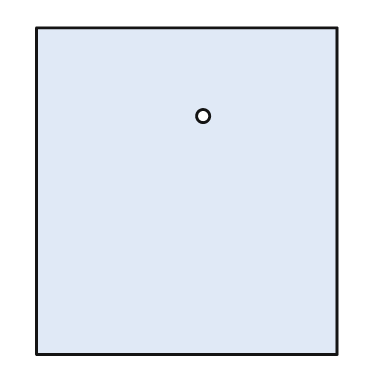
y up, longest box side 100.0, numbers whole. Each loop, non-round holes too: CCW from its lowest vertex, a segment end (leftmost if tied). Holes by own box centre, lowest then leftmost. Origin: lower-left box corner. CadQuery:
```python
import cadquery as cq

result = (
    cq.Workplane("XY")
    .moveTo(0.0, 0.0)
    .lineTo(92.0, 0.0)
    .lineTo(92.0, 100.0)
    .lineTo(0.0, 100.0)
    .close()
    .moveTo(51.0, 73.0)
    .circle(2.0)
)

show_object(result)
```